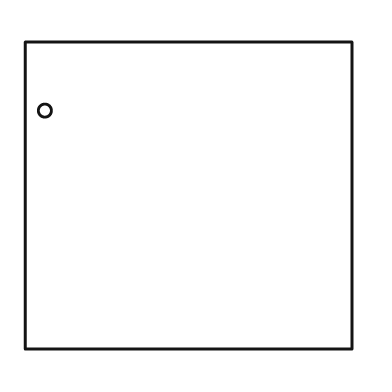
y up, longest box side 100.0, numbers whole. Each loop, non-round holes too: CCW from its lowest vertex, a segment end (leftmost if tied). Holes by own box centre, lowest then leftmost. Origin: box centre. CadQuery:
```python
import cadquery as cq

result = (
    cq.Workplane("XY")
    .moveTo(-50.0, -47.0)
    .lineTo(50.0, -47.0)
    .lineTo(50.0, 47.0)
    .lineTo(-50.0, 47.0)
    .close()
    .moveTo(-44.0, 26.0)
    .circle(2.0)
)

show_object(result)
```